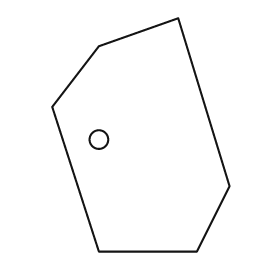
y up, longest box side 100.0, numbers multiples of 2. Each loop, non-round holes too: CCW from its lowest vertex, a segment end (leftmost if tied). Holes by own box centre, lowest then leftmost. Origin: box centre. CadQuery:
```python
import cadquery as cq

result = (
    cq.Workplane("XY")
    .moveTo(-18.0, -50.0)
    .lineTo(24.0, -50.0)
    .lineTo(38.0, -22.0)
    .lineTo(16.0, 50.0)
    .lineTo(-18.0, 38.0)
    .lineTo(-38.0, 12.0)
    .close()
    .moveTo(-18.0, -2.0)
    .circle(4.0)
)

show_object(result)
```